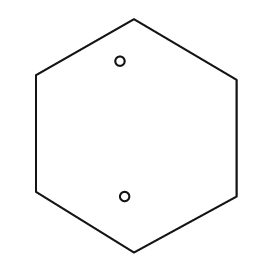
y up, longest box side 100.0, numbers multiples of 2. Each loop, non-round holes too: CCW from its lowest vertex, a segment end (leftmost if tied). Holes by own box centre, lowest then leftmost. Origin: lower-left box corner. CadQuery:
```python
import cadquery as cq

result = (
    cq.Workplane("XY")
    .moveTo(42.0, 0.0)
    .lineTo(86.0, 24.0)
    .lineTo(86.0, 74.0)
    .lineTo(42.0, 100.0)
    .lineTo(0.0, 76.0)
    .lineTo(0.0, 26.0)
    .close()
    .moveTo(38.0, 24.0)
    .circle(2.0)
    .moveTo(36.0, 82.0)
    .circle(2.0)
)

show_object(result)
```